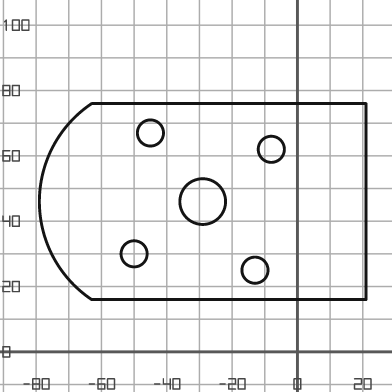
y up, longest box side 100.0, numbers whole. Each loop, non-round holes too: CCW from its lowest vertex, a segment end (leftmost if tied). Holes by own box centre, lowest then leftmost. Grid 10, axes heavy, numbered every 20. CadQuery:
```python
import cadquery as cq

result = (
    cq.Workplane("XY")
    .moveTo(-63.0, 16.0)
    .lineTo(21.0, 16.0)
    .lineTo(21.0, 76.0)
    .lineTo(-63.0, 76.0)
    .threePointArc((-79.0, 46.0), (-63.0, 16.0))
    .close()
    .moveTo(-13.0, 25.0)
    .circle(4.0)
    .moveTo(-50.0, 30.0)
    .circle(4.0)
    .moveTo(-29.0, 46.0)
    .circle(7.0)
    .moveTo(-8.0, 62.0)
    .circle(4.0)
    .moveTo(-45.0, 67.0)
    .circle(4.0)
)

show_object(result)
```